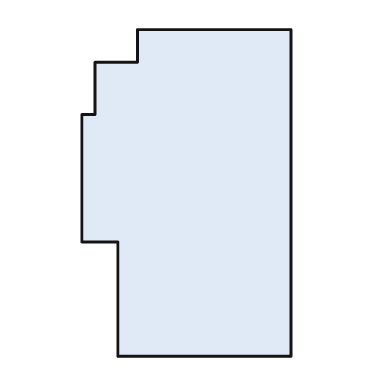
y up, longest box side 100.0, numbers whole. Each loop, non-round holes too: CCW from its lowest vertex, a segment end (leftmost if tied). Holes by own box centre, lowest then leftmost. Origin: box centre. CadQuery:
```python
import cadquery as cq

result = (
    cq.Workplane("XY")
    .moveTo(-21.0, -50.0)
    .lineTo(32.0, -50.0)
    .lineTo(32.0, 50.0)
    .lineTo(-15.0, 50.0)
    .lineTo(-15.0, 40.0)
    .lineTo(-28.0, 40.0)
    .lineTo(-28.0, 24.0)
    .lineTo(-32.0, 24.0)
    .lineTo(-32.0, -15.0)
    .lineTo(-21.0, -15.0)
    .close()
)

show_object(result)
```